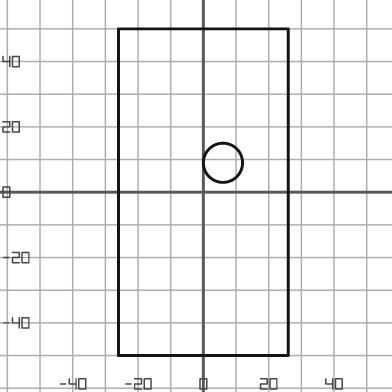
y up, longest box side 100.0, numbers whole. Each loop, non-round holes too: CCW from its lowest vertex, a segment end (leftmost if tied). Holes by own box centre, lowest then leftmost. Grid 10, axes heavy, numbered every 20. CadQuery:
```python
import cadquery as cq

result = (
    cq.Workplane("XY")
    .moveTo(-26.0, -50.0)
    .lineTo(26.0, -50.0)
    .lineTo(26.0, 50.0)
    .lineTo(-26.0, 50.0)
    .close()
    .moveTo(6.0, 9.0)
    .circle(6.0)
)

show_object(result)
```